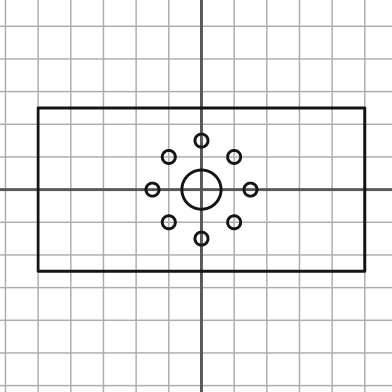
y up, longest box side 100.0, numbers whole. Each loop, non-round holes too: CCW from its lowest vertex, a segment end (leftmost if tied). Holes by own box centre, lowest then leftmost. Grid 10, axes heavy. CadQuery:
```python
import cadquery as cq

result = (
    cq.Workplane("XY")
    .moveTo(-50.0, -25.0)
    .lineTo(50.0, -25.0)
    .lineTo(50.0, 25.0)
    .lineTo(-50.0, 25.0)
    .close()
    .moveTo(0.0, -15.0)
    .circle(2.0)
    .moveTo(-10.0, -10.0)
    .circle(2.0)
    .moveTo(10.0, -10.0)
    .circle(2.0)
    .moveTo(-15.0, 0.0)
    .circle(2.0)
    .moveTo(0.0, 0.0)
    .circle(6.0)
    .moveTo(15.0, 0.0)
    .circle(2.0)
    .moveTo(-10.0, 10.0)
    .circle(2.0)
    .moveTo(10.0, 10.0)
    .circle(2.0)
    .moveTo(0.0, 15.0)
    .circle(2.0)
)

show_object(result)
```